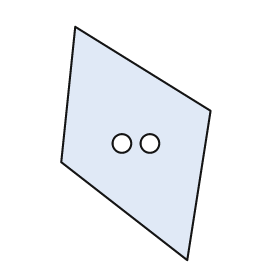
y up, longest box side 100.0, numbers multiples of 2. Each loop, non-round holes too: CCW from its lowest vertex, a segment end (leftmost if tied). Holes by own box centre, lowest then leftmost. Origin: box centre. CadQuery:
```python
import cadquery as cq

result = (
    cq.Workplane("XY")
    .moveTo(22.0, -50.0)
    .lineTo(32.0, 14.0)
    .lineTo(-26.0, 50.0)
    .lineTo(-32.0, -8.0)
    .close()
    .moveTo(-6.0, 0.0)
    .circle(4.0)
    .moveTo(6.0, 0.0)
    .circle(4.0)
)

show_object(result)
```